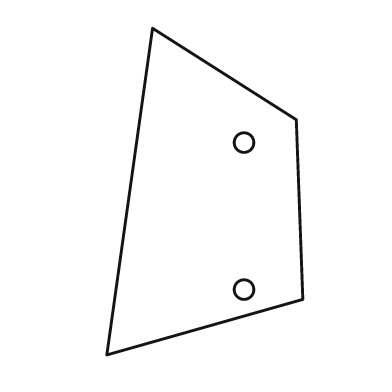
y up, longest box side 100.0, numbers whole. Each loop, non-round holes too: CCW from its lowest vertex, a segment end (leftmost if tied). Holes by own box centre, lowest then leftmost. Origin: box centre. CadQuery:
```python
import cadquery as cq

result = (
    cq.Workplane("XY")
    .moveTo(-30.0, -50.0)
    .lineTo(30.0, -33.0)
    .lineTo(28.0, 22.0)
    .lineTo(-16.0, 50.0)
    .close()
    .moveTo(12.0, -30.0)
    .circle(3.0)
    .moveTo(12.0, 15.0)
    .circle(3.0)
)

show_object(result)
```